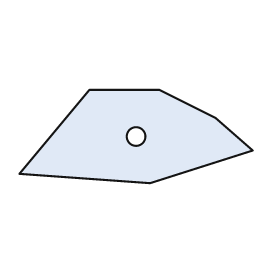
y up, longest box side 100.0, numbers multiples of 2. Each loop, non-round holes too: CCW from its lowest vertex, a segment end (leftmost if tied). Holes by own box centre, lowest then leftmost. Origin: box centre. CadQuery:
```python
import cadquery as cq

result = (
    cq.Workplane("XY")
    .moveTo(6.0, -20.0)
    .lineTo(50.0, -6.0)
    .lineTo(34.0, 8.0)
    .lineTo(10.0, 20.0)
    .lineTo(-20.0, 20.0)
    .lineTo(-50.0, -16.0)
    .close()
    .moveTo(0.0, 0.0)
    .circle(4.0)
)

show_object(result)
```